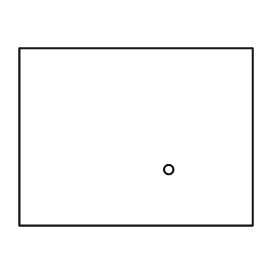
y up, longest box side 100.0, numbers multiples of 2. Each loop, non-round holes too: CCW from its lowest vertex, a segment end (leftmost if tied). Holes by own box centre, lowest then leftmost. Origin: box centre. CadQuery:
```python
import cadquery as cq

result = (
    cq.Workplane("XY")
    .moveTo(-50.0, -38.0)
    .lineTo(50.0, -38.0)
    .lineTo(50.0, 38.0)
    .lineTo(-50.0, 38.0)
    .close()
    .moveTo(14.0, -14.0)
    .circle(2.0)
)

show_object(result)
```